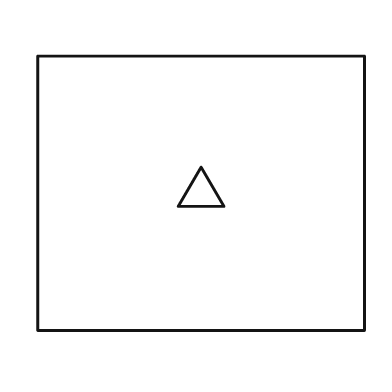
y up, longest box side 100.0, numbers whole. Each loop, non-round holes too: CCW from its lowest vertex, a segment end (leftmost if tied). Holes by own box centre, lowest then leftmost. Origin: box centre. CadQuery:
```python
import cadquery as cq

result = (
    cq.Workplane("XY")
    .moveTo(-50.0, -42.0)
    .lineTo(50.0, -42.0)
    .lineTo(50.0, 42.0)
    .lineTo(-50.0, 42.0)
    .close()
    .moveTo(-7.0, -4.0)
    .lineTo(7.0, -4.0)
    .lineTo(0.0, 8.0)
    .close()
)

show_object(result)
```